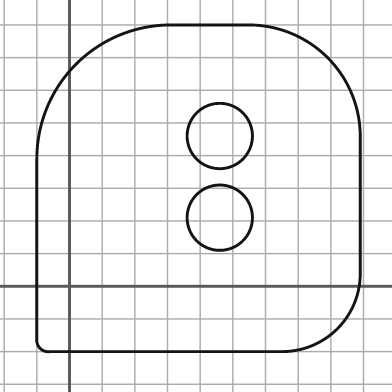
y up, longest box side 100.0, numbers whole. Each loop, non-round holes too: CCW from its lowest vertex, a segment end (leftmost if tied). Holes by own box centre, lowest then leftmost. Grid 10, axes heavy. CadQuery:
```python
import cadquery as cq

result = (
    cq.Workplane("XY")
    .moveTo(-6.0, -20.0)
    .lineTo(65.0, -20.0)
    .threePointArc((82.0, -13.0), (89.0, 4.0))
    .lineTo(89.0, 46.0)
    .threePointArc((79.0, 70.0), (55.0, 80.0))
    .lineTo(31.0, 80.0)
    .threePointArc((2.0, 68.0), (-10.0, 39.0))
    .lineTo(-10.0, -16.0)
    .threePointArc((-9.0, -19.0), (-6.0, -20.0))
    .close()
    .moveTo(46.0, 21.0)
    .circle(10.0)
    .moveTo(46.0, 46.0)
    .circle(10.0)
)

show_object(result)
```